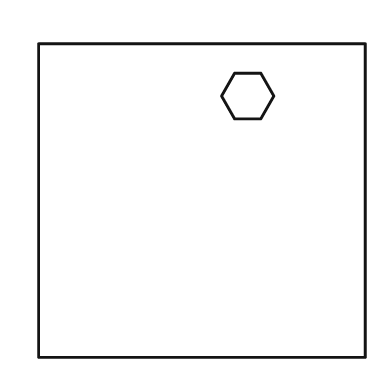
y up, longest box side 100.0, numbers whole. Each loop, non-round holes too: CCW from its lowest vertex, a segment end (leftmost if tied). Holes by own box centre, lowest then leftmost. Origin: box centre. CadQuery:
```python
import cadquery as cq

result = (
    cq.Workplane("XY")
    .moveTo(-50.0, -48.0)
    .lineTo(50.0, -48.0)
    .lineTo(50.0, 48.0)
    .lineTo(-50.0, 48.0)
    .close()
    .moveTo(10.0, 25.0)
    .lineTo(18.0, 25.0)
    .lineTo(22.0, 32.0)
    .lineTo(18.0, 39.0)
    .lineTo(10.0, 39.0)
    .lineTo(6.0, 32.0)
    .close()
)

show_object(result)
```